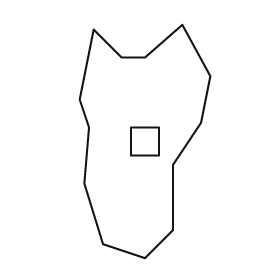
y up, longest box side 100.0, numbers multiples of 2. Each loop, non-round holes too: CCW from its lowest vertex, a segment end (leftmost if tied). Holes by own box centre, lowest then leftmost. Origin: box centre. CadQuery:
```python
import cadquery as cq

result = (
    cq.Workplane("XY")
    .moveTo(0.0, -50.0)
    .lineTo(12.0, -38.0)
    .lineTo(12.0, -10.0)
    .lineTo(24.0, 8.0)
    .lineTo(28.0, 28.0)
    .lineTo(16.0, 50.0)
    .lineTo(0.0, 36.0)
    .lineTo(-10.0, 36.0)
    .lineTo(-22.0, 48.0)
    .lineTo(-28.0, 18.0)
    .lineTo(-24.0, 6.0)
    .lineTo(-26.0, -18.0)
    .lineTo(-18.0, -44.0)
    .close()
    .moveTo(-6.0, -6.0)
    .lineTo(6.0, -6.0)
    .lineTo(6.0, 6.0)
    .lineTo(-6.0, 6.0)
    .close()
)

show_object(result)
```